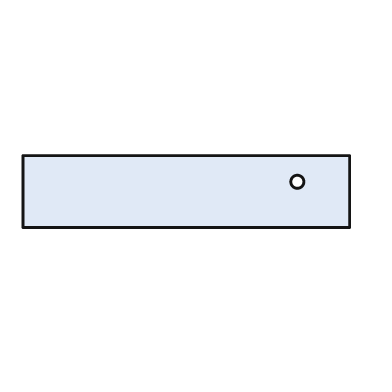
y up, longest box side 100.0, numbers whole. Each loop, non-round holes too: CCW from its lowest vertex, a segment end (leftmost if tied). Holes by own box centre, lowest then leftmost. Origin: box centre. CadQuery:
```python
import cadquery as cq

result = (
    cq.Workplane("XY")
    .moveTo(-50.0, -11.0)
    .lineTo(50.0, -11.0)
    .lineTo(50.0, 11.0)
    .lineTo(-50.0, 11.0)
    .close()
    .moveTo(34.0, 3.0)
    .circle(2.0)
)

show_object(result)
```